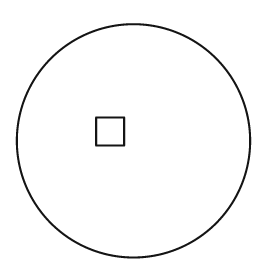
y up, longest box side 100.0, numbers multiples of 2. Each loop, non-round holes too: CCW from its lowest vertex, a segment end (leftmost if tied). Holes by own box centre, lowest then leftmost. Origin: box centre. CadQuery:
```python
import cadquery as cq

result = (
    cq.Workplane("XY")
    .moveTo(0.0, 0.0)
    .circle(50.0)
    .moveTo(-16.0, -2.0)
    .lineTo(-4.0, -2.0)
    .lineTo(-4.0, 10.0)
    .lineTo(-16.0, 10.0)
    .close()
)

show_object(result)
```